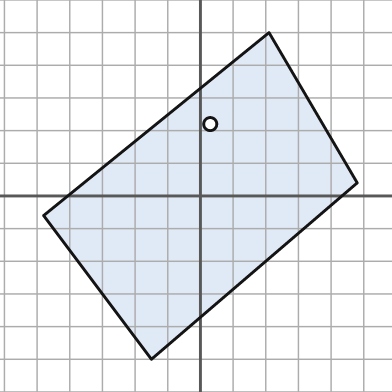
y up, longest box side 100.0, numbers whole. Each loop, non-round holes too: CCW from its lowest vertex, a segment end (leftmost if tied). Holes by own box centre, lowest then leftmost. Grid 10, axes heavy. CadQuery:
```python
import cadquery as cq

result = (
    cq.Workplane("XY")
    .moveTo(-15.0, -50.0)
    .lineTo(48.0, 4.0)
    .lineTo(21.0, 50.0)
    .lineTo(-48.0, -6.0)
    .close()
    .moveTo(3.0, 22.0)
    .circle(2.0)
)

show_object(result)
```